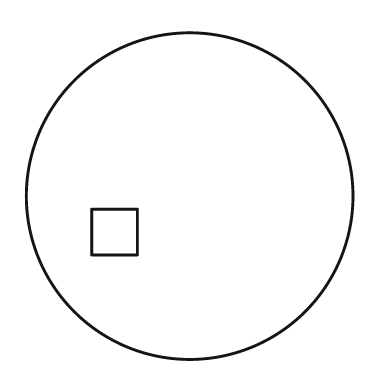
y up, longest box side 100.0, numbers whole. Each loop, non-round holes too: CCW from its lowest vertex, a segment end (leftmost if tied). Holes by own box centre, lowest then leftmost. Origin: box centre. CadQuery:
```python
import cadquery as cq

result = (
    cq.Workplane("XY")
    .moveTo(0.0, 0.0)
    .circle(50.0)
    .moveTo(-30.0, -18.0)
    .lineTo(-16.0, -18.0)
    .lineTo(-16.0, -4.0)
    .lineTo(-30.0, -4.0)
    .close()
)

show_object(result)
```